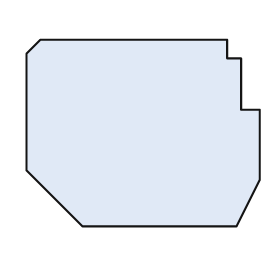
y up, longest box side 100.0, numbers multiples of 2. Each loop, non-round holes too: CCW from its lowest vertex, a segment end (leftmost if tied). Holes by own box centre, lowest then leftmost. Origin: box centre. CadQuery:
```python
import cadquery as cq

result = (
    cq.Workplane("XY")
    .moveTo(-26.0, -40.0)
    .lineTo(40.0, -40.0)
    .lineTo(50.0, -20.0)
    .lineTo(50.0, 10.0)
    .lineTo(42.0, 10.0)
    .lineTo(42.0, 32.0)
    .lineTo(36.0, 32.0)
    .lineTo(36.0, 40.0)
    .lineTo(-44.0, 40.0)
    .lineTo(-50.0, 34.0)
    .lineTo(-50.0, -16.0)
    .close()
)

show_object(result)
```